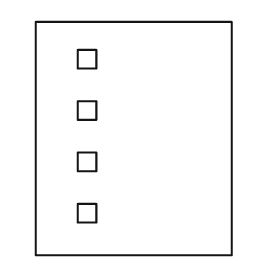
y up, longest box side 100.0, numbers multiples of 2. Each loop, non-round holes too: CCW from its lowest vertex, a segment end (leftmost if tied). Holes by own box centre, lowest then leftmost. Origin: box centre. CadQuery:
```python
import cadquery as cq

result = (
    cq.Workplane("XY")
    .moveTo(-42.0, -50.0)
    .lineTo(42.0, -50.0)
    .lineTo(42.0, 50.0)
    .lineTo(-42.0, 50.0)
    .close()
    .moveTo(-24.0, -36.0)
    .lineTo(-16.0, -36.0)
    .lineTo(-16.0, -28.0)
    .lineTo(-24.0, -28.0)
    .close()
    .moveTo(-24.0, -14.0)
    .lineTo(-16.0, -14.0)
    .lineTo(-16.0, -6.0)
    .lineTo(-24.0, -6.0)
    .close()
    .moveTo(-24.0, 8.0)
    .lineTo(-16.0, 8.0)
    .lineTo(-16.0, 16.0)
    .lineTo(-24.0, 16.0)
    .close()
    .moveTo(-24.0, 30.0)
    .lineTo(-16.0, 30.0)
    .lineTo(-16.0, 38.0)
    .lineTo(-24.0, 38.0)
    .close()
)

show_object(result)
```